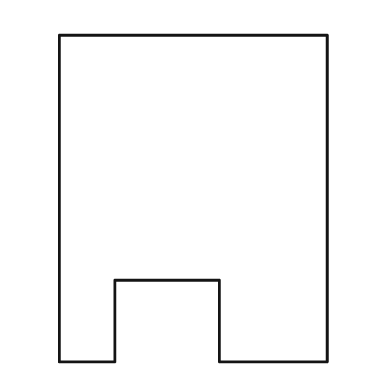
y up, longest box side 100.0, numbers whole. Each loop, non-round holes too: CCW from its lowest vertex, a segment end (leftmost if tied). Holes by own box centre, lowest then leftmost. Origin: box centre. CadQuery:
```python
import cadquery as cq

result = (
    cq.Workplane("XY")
    .moveTo(-41.0, -50.0)
    .lineTo(-24.0, -50.0)
    .lineTo(-24.0, -25.0)
    .lineTo(8.0, -25.0)
    .lineTo(8.0, -50.0)
    .lineTo(41.0, -50.0)
    .lineTo(41.0, 50.0)
    .lineTo(-41.0, 50.0)
    .close()
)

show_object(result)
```